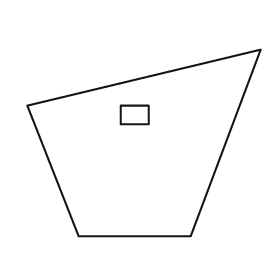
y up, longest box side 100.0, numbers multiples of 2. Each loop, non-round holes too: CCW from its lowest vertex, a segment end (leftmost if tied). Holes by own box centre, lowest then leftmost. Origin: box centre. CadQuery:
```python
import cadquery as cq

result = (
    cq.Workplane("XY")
    .moveTo(-28.0, -40.0)
    .lineTo(20.0, -40.0)
    .lineTo(50.0, 40.0)
    .lineTo(-50.0, 16.0)
    .close()
    .moveTo(-10.0, 8.0)
    .lineTo(2.0, 8.0)
    .lineTo(2.0, 16.0)
    .lineTo(-10.0, 16.0)
    .close()
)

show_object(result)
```